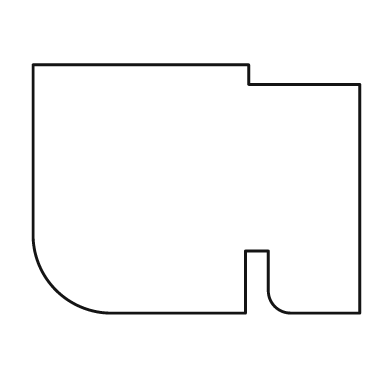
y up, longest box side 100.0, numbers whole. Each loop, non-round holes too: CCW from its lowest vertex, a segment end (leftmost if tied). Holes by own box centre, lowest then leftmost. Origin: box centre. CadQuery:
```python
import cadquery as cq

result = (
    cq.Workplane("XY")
    .moveTo(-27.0, -38.0)
    .lineTo(15.0, -38.0)
    .lineTo(15.0, -19.0)
    .lineTo(22.0, -19.0)
    .lineTo(22.0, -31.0)
    .threePointArc((24.0, -36.0), (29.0, -38.0))
    .lineTo(50.0, -38.0)
    .lineTo(50.0, 32.0)
    .lineTo(16.0, 32.0)
    .lineTo(16.0, 38.0)
    .lineTo(-50.0, 38.0)
    .lineTo(-50.0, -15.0)
    .threePointArc((-43.0, -31.0), (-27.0, -38.0))
    .close()
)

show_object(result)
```